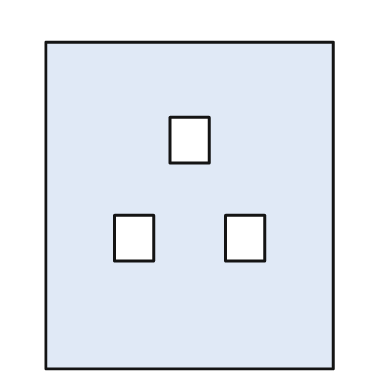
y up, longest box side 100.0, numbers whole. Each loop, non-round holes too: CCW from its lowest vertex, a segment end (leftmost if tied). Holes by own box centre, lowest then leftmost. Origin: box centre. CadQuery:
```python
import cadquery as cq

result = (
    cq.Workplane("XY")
    .moveTo(-44.0, -50.0)
    .lineTo(44.0, -50.0)
    .lineTo(44.0, 50.0)
    .lineTo(-44.0, 50.0)
    .close()
    .moveTo(-23.0, -17.0)
    .lineTo(-11.0, -17.0)
    .lineTo(-11.0, -3.0)
    .lineTo(-23.0, -3.0)
    .close()
    .moveTo(11.0, -17.0)
    .lineTo(23.0, -17.0)
    .lineTo(23.0, -3.0)
    .lineTo(11.0, -3.0)
    .close()
    .moveTo(-6.0, 13.0)
    .lineTo(6.0, 13.0)
    .lineTo(6.0, 27.0)
    .lineTo(-6.0, 27.0)
    .close()
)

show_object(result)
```